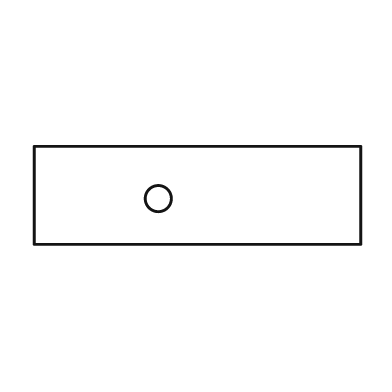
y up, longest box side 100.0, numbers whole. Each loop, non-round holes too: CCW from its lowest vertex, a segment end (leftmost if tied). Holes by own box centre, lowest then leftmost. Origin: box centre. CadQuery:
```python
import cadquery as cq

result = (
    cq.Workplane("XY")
    .moveTo(-50.0, -15.0)
    .lineTo(50.0, -15.0)
    .lineTo(50.0, 15.0)
    .lineTo(-50.0, 15.0)
    .close()
    .moveTo(-12.0, -1.0)
    .circle(4.0)
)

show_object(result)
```